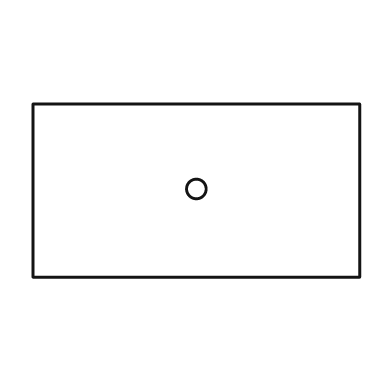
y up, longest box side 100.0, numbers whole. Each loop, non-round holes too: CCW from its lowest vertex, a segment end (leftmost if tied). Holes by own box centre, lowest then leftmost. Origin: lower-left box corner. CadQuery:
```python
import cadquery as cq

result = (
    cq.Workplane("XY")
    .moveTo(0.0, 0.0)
    .lineTo(100.0, 0.0)
    .lineTo(100.0, 53.0)
    .lineTo(0.0, 53.0)
    .close()
    .moveTo(50.0, 27.0)
    .circle(3.0)
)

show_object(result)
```